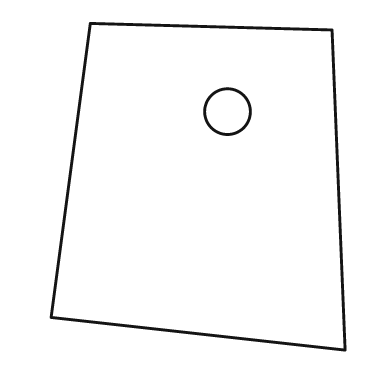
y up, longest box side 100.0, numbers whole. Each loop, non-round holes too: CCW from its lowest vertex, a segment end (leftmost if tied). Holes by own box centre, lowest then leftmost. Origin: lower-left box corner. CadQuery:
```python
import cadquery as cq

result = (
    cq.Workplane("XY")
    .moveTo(90.0, 0.0)
    .lineTo(86.0, 98.0)
    .lineTo(12.0, 100.0)
    .lineTo(0.0, 10.0)
    .close()
    .moveTo(54.0, 73.0)
    .circle(7.0)
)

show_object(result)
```